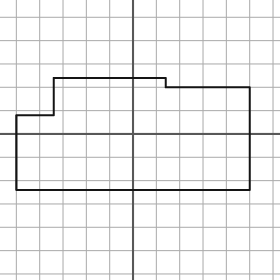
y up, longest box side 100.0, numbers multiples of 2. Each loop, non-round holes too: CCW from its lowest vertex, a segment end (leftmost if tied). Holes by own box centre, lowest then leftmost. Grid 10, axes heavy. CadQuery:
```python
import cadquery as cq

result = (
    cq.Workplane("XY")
    .moveTo(-50.0, -24.0)
    .lineTo(50.0, -24.0)
    .lineTo(50.0, 20.0)
    .lineTo(14.0, 20.0)
    .lineTo(14.0, 24.0)
    .lineTo(-34.0, 24.0)
    .lineTo(-34.0, 8.0)
    .lineTo(-50.0, 8.0)
    .close()
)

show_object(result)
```